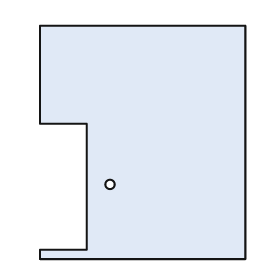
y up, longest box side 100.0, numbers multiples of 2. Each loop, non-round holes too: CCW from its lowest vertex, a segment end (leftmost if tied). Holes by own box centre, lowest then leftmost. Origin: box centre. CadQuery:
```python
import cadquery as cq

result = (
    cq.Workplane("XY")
    .moveTo(-44.0, -50.0)
    .lineTo(44.0, -50.0)
    .lineTo(44.0, 50.0)
    .lineTo(-44.0, 50.0)
    .lineTo(-44.0, 8.0)
    .lineTo(-24.0, 8.0)
    .lineTo(-24.0, -46.0)
    .lineTo(-44.0, -46.0)
    .close()
    .moveTo(-14.0, -18.0)
    .circle(2.0)
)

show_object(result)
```